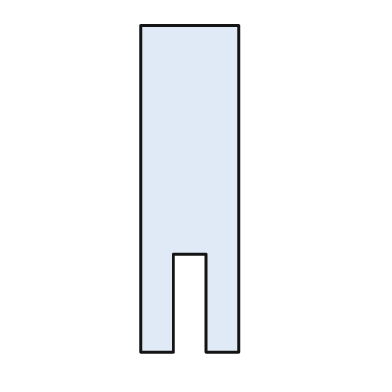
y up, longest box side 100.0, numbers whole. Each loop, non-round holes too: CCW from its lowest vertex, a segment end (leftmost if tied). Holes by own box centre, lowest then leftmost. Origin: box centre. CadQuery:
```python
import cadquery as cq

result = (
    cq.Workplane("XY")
    .moveTo(-15.0, -50.0)
    .lineTo(-5.0, -50.0)
    .lineTo(-5.0, -20.0)
    .lineTo(5.0, -20.0)
    .lineTo(5.0, -50.0)
    .lineTo(15.0, -50.0)
    .lineTo(15.0, 50.0)
    .lineTo(-15.0, 50.0)
    .close()
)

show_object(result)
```